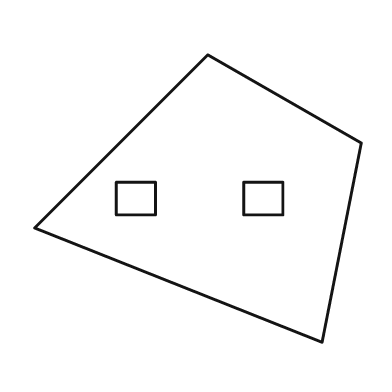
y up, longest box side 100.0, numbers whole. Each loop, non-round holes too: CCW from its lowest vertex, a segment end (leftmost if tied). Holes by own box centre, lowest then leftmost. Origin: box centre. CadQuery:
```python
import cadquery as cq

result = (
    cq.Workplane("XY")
    .moveTo(38.0, -44.0)
    .lineTo(50.0, 17.0)
    .lineTo(3.0, 44.0)
    .lineTo(-50.0, -9.0)
    .close()
    .moveTo(-25.0, -5.0)
    .lineTo(-13.0, -5.0)
    .lineTo(-13.0, 5.0)
    .lineTo(-25.0, 5.0)
    .close()
    .moveTo(14.0, -5.0)
    .lineTo(26.0, -5.0)
    .lineTo(26.0, 5.0)
    .lineTo(14.0, 5.0)
    .close()
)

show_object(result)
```